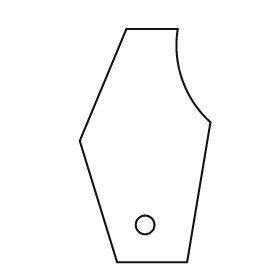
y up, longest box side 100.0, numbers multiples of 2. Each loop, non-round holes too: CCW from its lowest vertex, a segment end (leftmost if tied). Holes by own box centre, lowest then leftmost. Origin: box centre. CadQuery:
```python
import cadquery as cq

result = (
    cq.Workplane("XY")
    .moveTo(-12.0, -50.0)
    .lineTo(18.0, -50.0)
    .lineTo(28.0, 10.0)
    .threePointArc((16.0, 28.0), (14.0, 50.0))
    .lineTo(-8.0, 50.0)
    .lineTo(-28.0, 2.0)
    .close()
    .moveTo(0.0, -34.0)
    .circle(4.0)
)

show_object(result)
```